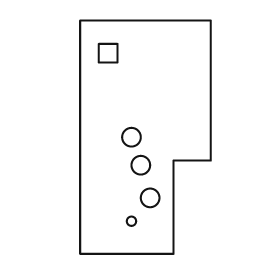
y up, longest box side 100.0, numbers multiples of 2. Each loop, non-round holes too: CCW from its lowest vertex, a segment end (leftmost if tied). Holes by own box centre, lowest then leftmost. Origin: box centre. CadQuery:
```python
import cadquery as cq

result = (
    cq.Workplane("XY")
    .moveTo(-28.0, -50.0)
    .lineTo(12.0, -50.0)
    .lineTo(12.0, -10.0)
    .lineTo(28.0, -10.0)
    .lineTo(28.0, 50.0)
    .lineTo(-28.0, 50.0)
    .close()
    .moveTo(-6.0, -36.0)
    .circle(2.0)
    .moveTo(2.0, -26.0)
    .circle(4.0)
    .moveTo(-2.0, -12.0)
    .circle(4.0)
    .moveTo(-6.0, 0.0)
    .circle(4.0)
    .moveTo(-20.0, 32.0)
    .lineTo(-12.0, 32.0)
    .lineTo(-12.0, 40.0)
    .lineTo(-20.0, 40.0)
    .close()
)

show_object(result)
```